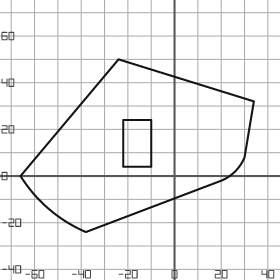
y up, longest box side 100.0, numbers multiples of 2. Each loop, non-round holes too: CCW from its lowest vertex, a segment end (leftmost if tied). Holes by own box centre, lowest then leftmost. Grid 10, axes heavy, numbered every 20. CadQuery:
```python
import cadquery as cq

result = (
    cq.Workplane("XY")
    .moveTo(-38.0, -24.0)
    .lineTo(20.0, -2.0)
    .threePointArc((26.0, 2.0), (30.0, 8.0))
    .lineTo(34.0, 32.0)
    .lineTo(-24.0, 50.0)
    .lineTo(-66.0, 0.0)
    .threePointArc((-54.0, -14.0), (-38.0, -24.0))
    .close()
    .moveTo(-22.0, 4.0)
    .lineTo(-10.0, 4.0)
    .lineTo(-10.0, 24.0)
    .lineTo(-22.0, 24.0)
    .close()
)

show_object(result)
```